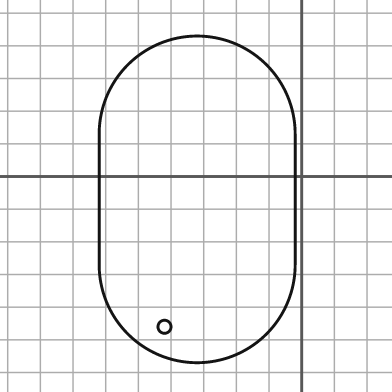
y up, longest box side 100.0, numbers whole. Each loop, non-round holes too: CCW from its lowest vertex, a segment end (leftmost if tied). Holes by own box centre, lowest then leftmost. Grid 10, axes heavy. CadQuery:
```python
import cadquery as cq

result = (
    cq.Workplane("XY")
    .moveTo(-62.0, -27.0)
    .threePointArc((-32.0, -57.0), (-2.0, -27.0))
    .lineTo(-2.0, 13.0)
    .threePointArc((-32.0, 43.0), (-62.0, 13.0))
    .close()
    .moveTo(-42.0, -46.0)
    .circle(2.0)
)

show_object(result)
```